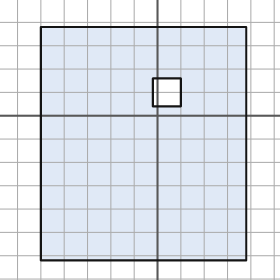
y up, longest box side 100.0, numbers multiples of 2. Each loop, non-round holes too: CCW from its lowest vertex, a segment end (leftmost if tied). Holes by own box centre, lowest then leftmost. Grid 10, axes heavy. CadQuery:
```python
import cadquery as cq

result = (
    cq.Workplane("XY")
    .moveTo(-50.0, -62.0)
    .lineTo(38.0, -62.0)
    .lineTo(38.0, 38.0)
    .lineTo(-50.0, 38.0)
    .close()
    .moveTo(-2.0, 4.0)
    .lineTo(10.0, 4.0)
    .lineTo(10.0, 16.0)
    .lineTo(-2.0, 16.0)
    .close()
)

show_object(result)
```